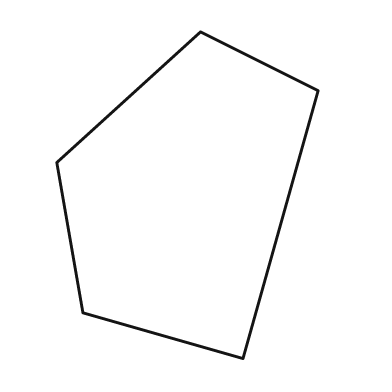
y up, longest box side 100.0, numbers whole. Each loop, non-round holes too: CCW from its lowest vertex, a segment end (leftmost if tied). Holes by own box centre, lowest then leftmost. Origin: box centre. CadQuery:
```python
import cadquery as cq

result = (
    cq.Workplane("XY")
    .moveTo(17.0, -50.0)
    .lineTo(40.0, 32.0)
    .lineTo(4.0, 50.0)
    .lineTo(-40.0, 10.0)
    .lineTo(-32.0, -36.0)
    .close()
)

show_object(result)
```